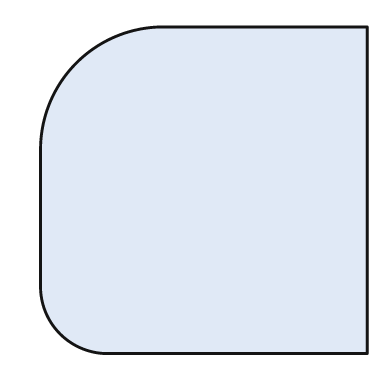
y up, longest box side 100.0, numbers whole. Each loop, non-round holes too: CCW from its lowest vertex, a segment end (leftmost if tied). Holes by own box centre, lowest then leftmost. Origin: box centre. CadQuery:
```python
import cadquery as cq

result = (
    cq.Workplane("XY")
    .moveTo(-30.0, -50.0)
    .lineTo(50.0, -50.0)
    .lineTo(50.0, 50.0)
    .lineTo(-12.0, 50.0)
    .threePointArc((-39.0, 39.0), (-50.0, 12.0))
    .lineTo(-50.0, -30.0)
    .threePointArc((-44.0, -44.0), (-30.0, -50.0))
    .close()
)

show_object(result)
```